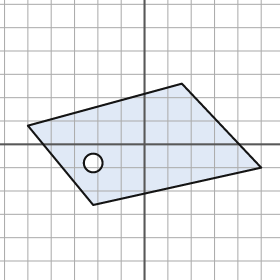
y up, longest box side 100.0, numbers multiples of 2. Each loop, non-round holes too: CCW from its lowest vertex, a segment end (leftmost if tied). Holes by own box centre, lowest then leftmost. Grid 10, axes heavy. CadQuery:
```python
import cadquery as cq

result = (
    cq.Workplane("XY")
    .moveTo(-22.0, -26.0)
    .lineTo(50.0, -10.0)
    .lineTo(16.0, 26.0)
    .lineTo(-50.0, 8.0)
    .close()
    .moveTo(-22.0, -8.0)
    .circle(4.0)
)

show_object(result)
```